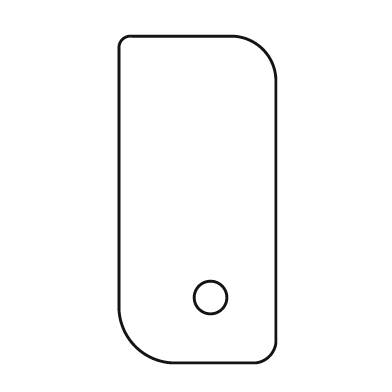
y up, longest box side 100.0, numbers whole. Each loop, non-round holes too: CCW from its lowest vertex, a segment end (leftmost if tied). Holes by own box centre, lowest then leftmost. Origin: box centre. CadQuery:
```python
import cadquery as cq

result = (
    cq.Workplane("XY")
    .moveTo(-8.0, -50.0)
    .lineTo(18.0, -50.0)
    .threePointArc((22.0, -48.0), (24.0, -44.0))
    .lineTo(24.0, 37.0)
    .threePointArc((20.0, 46.0), (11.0, 50.0))
    .lineTo(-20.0, 50.0)
    .threePointArc((-23.0, 49.0), (-24.0, 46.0))
    .lineTo(-24.0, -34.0)
    .threePointArc((-19.0, -45.0), (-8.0, -50.0))
    .close()
    .moveTo(4.0, -30.0)
    .circle(5.0)
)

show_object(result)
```